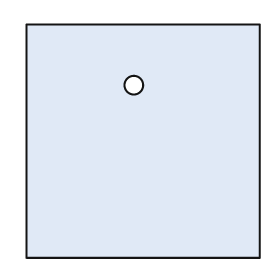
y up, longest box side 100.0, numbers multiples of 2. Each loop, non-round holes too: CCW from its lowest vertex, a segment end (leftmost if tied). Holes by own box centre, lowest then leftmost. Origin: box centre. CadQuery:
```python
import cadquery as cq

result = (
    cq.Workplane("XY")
    .moveTo(-50.0, -50.0)
    .lineTo(50.0, -50.0)
    .lineTo(50.0, 50.0)
    .lineTo(-50.0, 50.0)
    .close()
    .moveTo(-4.0, 24.0)
    .circle(4.0)
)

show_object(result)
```